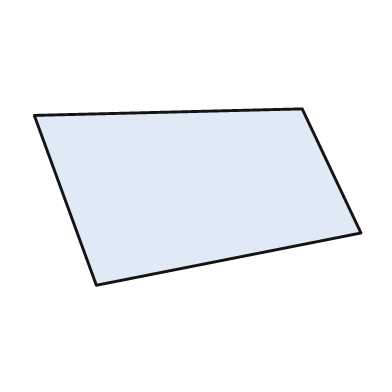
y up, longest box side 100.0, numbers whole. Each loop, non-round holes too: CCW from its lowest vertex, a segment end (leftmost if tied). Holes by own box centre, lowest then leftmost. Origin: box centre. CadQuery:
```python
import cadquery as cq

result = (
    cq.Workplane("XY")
    .moveTo(-31.0, -27.0)
    .lineTo(50.0, -11.0)
    .lineTo(32.0, 27.0)
    .lineTo(-50.0, 25.0)
    .close()
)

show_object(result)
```